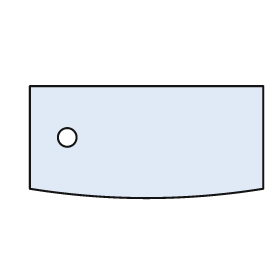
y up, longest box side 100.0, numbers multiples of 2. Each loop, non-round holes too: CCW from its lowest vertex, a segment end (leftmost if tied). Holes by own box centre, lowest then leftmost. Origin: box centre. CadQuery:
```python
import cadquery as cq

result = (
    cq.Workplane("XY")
    .moveTo(-50.0, -20.0)
    .threePointArc((0.0, -24.0), (50.0, -20.0))
    .lineTo(50.0, 24.0)
    .lineTo(-50.0, 24.0)
    .close()
    .moveTo(-34.0, 2.0)
    .circle(4.0)
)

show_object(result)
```